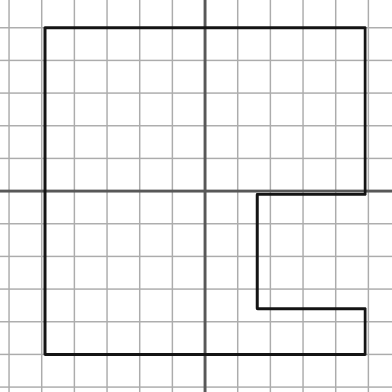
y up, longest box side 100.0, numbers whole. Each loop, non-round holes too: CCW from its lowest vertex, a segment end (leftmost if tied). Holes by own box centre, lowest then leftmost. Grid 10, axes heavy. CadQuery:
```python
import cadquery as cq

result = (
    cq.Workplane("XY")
    .moveTo(-49.0, -50.0)
    .lineTo(49.0, -50.0)
    .lineTo(49.0, -36.0)
    .lineTo(16.0, -36.0)
    .lineTo(16.0, -1.0)
    .lineTo(49.0, -1.0)
    .lineTo(49.0, 50.0)
    .lineTo(-49.0, 50.0)
    .close()
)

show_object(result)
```